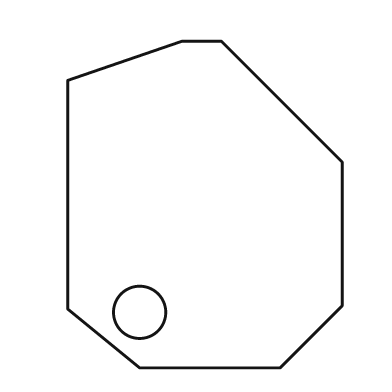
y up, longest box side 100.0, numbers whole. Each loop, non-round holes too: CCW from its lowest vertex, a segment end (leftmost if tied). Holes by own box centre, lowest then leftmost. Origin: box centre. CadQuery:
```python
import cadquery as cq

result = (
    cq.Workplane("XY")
    .moveTo(-20.0, -50.0)
    .lineTo(23.0, -50.0)
    .lineTo(42.0, -31.0)
    .lineTo(42.0, 13.0)
    .lineTo(5.0, 50.0)
    .lineTo(-7.0, 50.0)
    .lineTo(-42.0, 38.0)
    .lineTo(-42.0, -32.0)
    .close()
    .moveTo(-20.0, -33.0)
    .circle(8.0)
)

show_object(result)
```